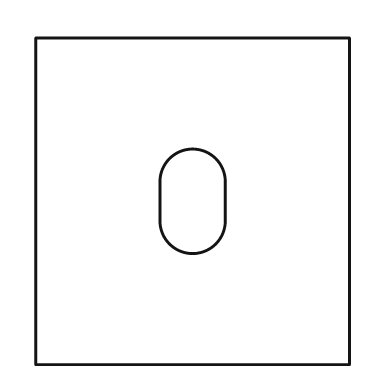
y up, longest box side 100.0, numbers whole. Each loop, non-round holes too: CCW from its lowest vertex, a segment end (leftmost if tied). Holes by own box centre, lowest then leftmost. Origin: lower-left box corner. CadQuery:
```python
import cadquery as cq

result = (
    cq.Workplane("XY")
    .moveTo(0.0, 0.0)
    .lineTo(96.0, 0.0)
    .lineTo(96.0, 100.0)
    .lineTo(0.0, 100.0)
    .close()
    .moveTo(38.0, 44.0)
    .threePointArc((48.0, 34.0), (58.0, 44.0))
    .lineTo(58.0, 56.0)
    .threePointArc((48.0, 66.0), (38.0, 56.0))
    .close()
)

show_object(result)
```